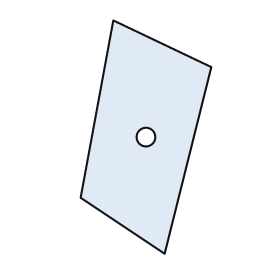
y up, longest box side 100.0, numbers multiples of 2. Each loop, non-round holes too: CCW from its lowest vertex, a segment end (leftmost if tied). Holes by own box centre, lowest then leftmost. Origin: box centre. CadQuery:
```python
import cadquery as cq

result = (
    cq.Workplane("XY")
    .moveTo(8.0, -50.0)
    .lineTo(28.0, 30.0)
    .lineTo(-14.0, 50.0)
    .lineTo(-28.0, -26.0)
    .close()
    .moveTo(0.0, 0.0)
    .circle(4.0)
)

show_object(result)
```